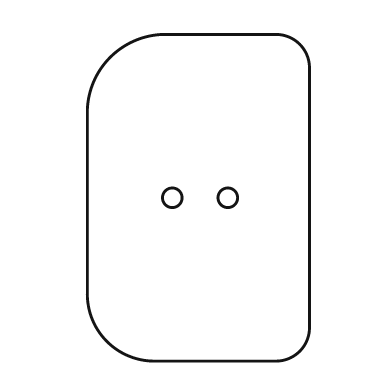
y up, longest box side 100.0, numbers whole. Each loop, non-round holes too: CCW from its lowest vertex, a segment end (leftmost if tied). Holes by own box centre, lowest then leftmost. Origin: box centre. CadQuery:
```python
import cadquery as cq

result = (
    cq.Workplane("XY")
    .moveTo(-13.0, -50.0)
    .lineTo(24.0, -50.0)
    .threePointArc((31.0, -47.0), (34.0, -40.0))
    .lineTo(34.0, 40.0)
    .threePointArc((31.0, 47.0), (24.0, 50.0))
    .lineTo(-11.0, 50.0)
    .threePointArc((-27.0, 43.0), (-34.0, 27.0))
    .lineTo(-34.0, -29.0)
    .threePointArc((-28.0, -44.0), (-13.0, -50.0))
    .close()
    .moveTo(-8.0, 0.0)
    .circle(3.0)
    .moveTo(9.0, 0.0)
    .circle(3.0)
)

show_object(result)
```